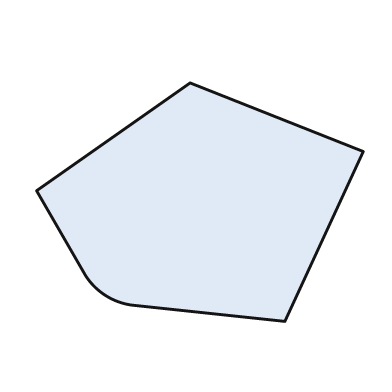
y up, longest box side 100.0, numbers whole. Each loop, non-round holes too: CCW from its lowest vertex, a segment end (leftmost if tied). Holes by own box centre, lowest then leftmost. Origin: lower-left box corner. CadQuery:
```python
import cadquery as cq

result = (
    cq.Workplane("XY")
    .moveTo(76.0, 0.0)
    .lineTo(100.0, 52.0)
    .lineTo(47.0, 73.0)
    .lineTo(0.0, 40.0)
    .lineTo(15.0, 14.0)
    .threePointArc((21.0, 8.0), (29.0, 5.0))
    .close()
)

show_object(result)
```